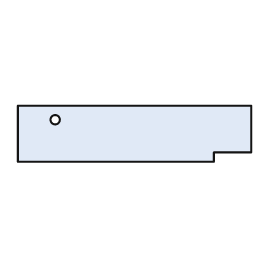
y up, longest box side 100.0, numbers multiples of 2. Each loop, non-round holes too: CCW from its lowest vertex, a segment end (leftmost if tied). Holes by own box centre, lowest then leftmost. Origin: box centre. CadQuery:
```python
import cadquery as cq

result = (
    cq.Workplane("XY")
    .moveTo(-50.0, -12.0)
    .lineTo(34.0, -12.0)
    .lineTo(34.0, -8.0)
    .lineTo(50.0, -8.0)
    .lineTo(50.0, 12.0)
    .lineTo(-50.0, 12.0)
    .close()
    .moveTo(-34.0, 6.0)
    .circle(2.0)
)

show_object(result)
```